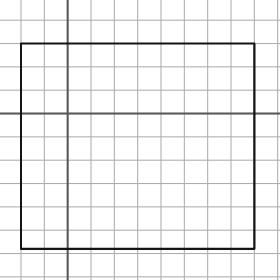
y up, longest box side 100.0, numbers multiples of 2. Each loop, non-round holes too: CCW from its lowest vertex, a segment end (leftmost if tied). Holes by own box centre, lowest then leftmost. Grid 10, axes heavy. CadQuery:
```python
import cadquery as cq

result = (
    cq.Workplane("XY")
    .moveTo(-20.0, -58.0)
    .lineTo(80.0, -58.0)
    .lineTo(80.0, 30.0)
    .lineTo(-20.0, 30.0)
    .close()
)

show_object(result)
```